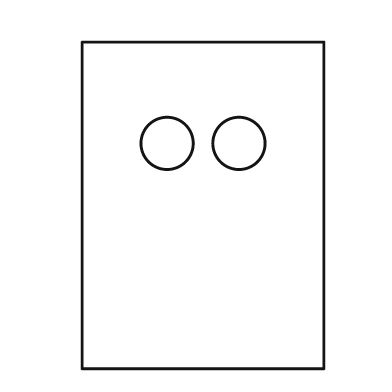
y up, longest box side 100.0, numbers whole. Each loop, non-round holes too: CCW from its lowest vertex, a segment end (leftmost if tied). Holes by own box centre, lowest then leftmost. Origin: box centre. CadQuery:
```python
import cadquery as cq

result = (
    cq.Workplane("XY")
    .moveTo(-37.0, -50.0)
    .lineTo(37.0, -50.0)
    .lineTo(37.0, 50.0)
    .lineTo(-37.0, 50.0)
    .close()
    .moveTo(-11.0, 19.0)
    .circle(8.0)
    .moveTo(11.0, 19.0)
    .circle(8.0)
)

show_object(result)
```